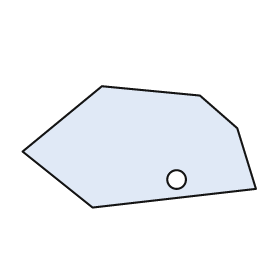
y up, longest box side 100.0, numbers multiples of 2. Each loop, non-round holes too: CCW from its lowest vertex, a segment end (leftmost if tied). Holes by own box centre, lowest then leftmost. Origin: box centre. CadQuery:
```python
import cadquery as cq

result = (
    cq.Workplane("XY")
    .moveTo(-20.0, -26.0)
    .lineTo(50.0, -18.0)
    .lineTo(42.0, 8.0)
    .lineTo(26.0, 22.0)
    .lineTo(-16.0, 26.0)
    .lineTo(-50.0, -2.0)
    .close()
    .moveTo(16.0, -14.0)
    .circle(4.0)
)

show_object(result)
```